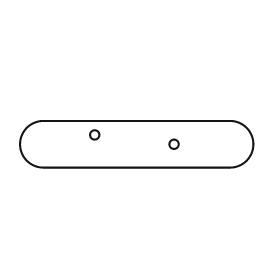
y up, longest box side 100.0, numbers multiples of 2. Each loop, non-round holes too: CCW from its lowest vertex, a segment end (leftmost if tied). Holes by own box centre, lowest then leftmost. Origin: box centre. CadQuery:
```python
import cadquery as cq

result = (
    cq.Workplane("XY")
    .moveTo(-40.0, -10.0)
    .lineTo(40.0, -10.0)
    .threePointArc((50.0, 0.0), (40.0, 10.0))
    .lineTo(-40.0, 10.0)
    .threePointArc((-50.0, 0.0), (-40.0, -10.0))
    .close()
    .moveTo(16.0, 0.0)
    .circle(2.0)
    .moveTo(-18.0, 4.0)
    .circle(2.0)
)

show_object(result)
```